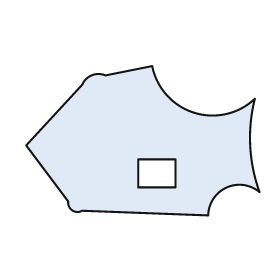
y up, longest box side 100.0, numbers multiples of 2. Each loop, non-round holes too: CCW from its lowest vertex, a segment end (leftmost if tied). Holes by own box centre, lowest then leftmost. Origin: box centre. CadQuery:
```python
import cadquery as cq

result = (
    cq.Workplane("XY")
    .moveTo(28.0, -32.0)
    .threePointArc((36.0, -20.0), (50.0, -22.0))
    .threePointArc((46.0, -2.0), (48.0, 18.0))
    .threePointArc((22.0, 12.0), (4.0, 32.0))
    .lineTo(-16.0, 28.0)
    .threePointArc((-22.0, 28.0), (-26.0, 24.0))
    .lineTo(-50.0, -2.0)
    .lineTo(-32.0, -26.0)
    .threePointArc((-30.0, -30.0), (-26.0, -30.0))
    .close()
    .moveTo(-2.0, -20.0)
    .lineTo(14.0, -20.0)
    .lineTo(14.0, -8.0)
    .lineTo(-2.0, -8.0)
    .close()
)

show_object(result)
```